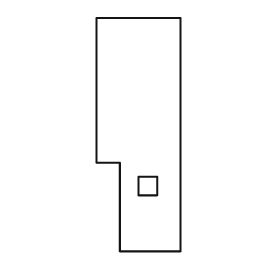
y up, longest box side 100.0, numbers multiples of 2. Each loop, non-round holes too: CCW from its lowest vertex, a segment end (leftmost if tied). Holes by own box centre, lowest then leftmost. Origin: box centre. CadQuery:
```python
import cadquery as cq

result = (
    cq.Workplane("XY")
    .moveTo(-8.0, -50.0)
    .lineTo(18.0, -50.0)
    .lineTo(18.0, 50.0)
    .lineTo(-18.0, 50.0)
    .lineTo(-18.0, -12.0)
    .lineTo(-8.0, -12.0)
    .close()
    .moveTo(0.0, -26.0)
    .lineTo(8.0, -26.0)
    .lineTo(8.0, -18.0)
    .lineTo(0.0, -18.0)
    .close()
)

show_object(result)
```